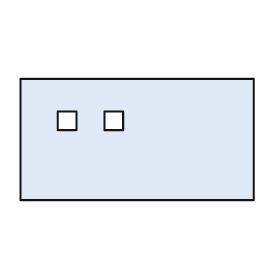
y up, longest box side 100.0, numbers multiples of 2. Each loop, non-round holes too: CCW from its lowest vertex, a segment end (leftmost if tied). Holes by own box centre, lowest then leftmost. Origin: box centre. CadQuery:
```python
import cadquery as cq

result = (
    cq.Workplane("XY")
    .moveTo(-50.0, -26.0)
    .lineTo(50.0, -26.0)
    .lineTo(50.0, 26.0)
    .lineTo(-50.0, 26.0)
    .close()
    .moveTo(-34.0, 4.0)
    .lineTo(-26.0, 4.0)
    .lineTo(-26.0, 12.0)
    .lineTo(-34.0, 12.0)
    .close()
    .moveTo(-14.0, 4.0)
    .lineTo(-6.0, 4.0)
    .lineTo(-6.0, 12.0)
    .lineTo(-14.0, 12.0)
    .close()
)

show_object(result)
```